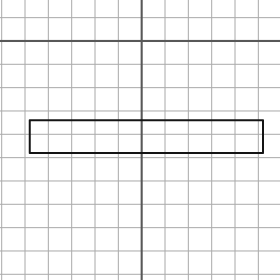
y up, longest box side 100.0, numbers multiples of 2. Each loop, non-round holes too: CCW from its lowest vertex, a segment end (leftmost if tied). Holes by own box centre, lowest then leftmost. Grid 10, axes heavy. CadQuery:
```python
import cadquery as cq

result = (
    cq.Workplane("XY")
    .moveTo(-48.0, -48.0)
    .lineTo(52.0, -48.0)
    .lineTo(52.0, -34.0)
    .lineTo(-48.0, -34.0)
    .close()
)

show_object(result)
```